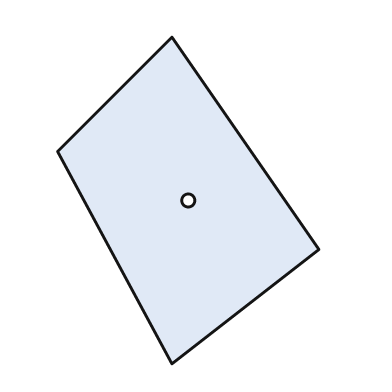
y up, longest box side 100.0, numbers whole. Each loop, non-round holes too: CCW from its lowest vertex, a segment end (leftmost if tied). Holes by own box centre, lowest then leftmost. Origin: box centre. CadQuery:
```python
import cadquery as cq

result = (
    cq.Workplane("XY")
    .moveTo(-5.0, -50.0)
    .lineTo(40.0, -15.0)
    .lineTo(-5.0, 50.0)
    .lineTo(-40.0, 15.0)
    .close()
    .moveTo(0.0, 0.0)
    .circle(2.0)
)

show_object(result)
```